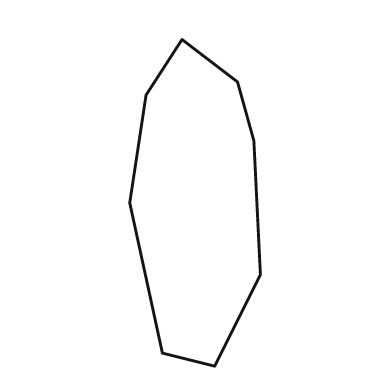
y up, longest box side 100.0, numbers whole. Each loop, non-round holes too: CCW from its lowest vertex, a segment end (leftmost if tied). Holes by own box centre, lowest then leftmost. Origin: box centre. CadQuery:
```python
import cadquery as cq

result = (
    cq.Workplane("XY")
    .moveTo(6.0, -50.0)
    .lineTo(20.0, -22.0)
    .lineTo(18.0, 19.0)
    .lineTo(13.0, 37.0)
    .lineTo(-4.0, 50.0)
    .lineTo(-15.0, 33.0)
    .lineTo(-20.0, 0.0)
    .lineTo(-10.0, -46.0)
    .close()
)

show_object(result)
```